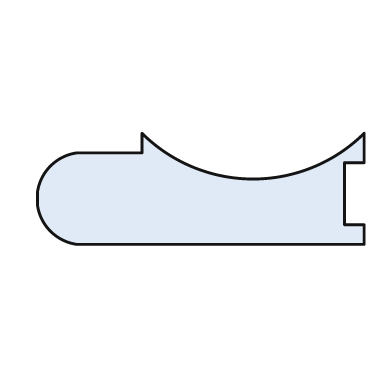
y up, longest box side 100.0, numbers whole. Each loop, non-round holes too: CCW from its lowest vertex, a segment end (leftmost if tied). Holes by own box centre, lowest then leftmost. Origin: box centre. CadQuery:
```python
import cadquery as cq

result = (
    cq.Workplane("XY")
    .moveTo(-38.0, -17.0)
    .lineTo(50.0, -17.0)
    .lineTo(50.0, -11.0)
    .lineTo(44.0, -11.0)
    .lineTo(44.0, 8.0)
    .lineTo(50.0, 8.0)
    .lineTo(50.0, 17.0)
    .threePointArc((16.0, 3.0), (-18.0, 17.0))
    .lineTo(-18.0, 11.0)
    .lineTo(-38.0, 11.0)
    .threePointArc((-46.0, 7.0), (-50.0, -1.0))
    .lineTo(-50.0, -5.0)
    .threePointArc((-46.0, -13.0), (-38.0, -17.0))
    .close()
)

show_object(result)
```